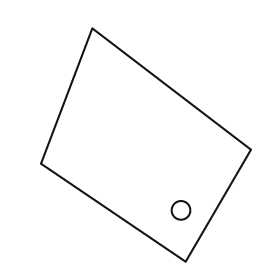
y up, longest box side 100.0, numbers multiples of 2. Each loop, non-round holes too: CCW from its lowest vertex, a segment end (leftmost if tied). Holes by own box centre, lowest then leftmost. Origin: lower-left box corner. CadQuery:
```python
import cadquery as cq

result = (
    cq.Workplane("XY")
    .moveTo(62.0, 0.0)
    .lineTo(90.0, 48.0)
    .lineTo(22.0, 100.0)
    .lineTo(0.0, 42.0)
    .close()
    .moveTo(60.0, 22.0)
    .circle(4.0)
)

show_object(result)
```